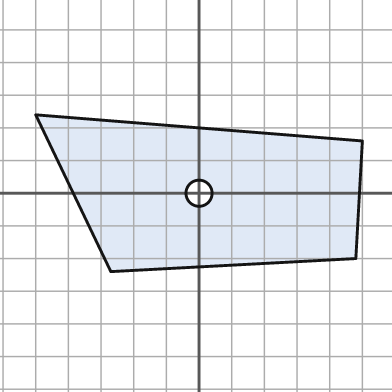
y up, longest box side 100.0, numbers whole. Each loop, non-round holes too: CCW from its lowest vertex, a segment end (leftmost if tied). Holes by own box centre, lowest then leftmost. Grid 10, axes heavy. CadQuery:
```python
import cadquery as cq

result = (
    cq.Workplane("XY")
    .moveTo(-27.0, -24.0)
    .lineTo(48.0, -20.0)
    .lineTo(50.0, 16.0)
    .lineTo(-50.0, 24.0)
    .close()
    .moveTo(0.0, 0.0)
    .circle(4.0)
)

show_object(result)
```